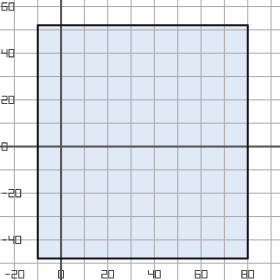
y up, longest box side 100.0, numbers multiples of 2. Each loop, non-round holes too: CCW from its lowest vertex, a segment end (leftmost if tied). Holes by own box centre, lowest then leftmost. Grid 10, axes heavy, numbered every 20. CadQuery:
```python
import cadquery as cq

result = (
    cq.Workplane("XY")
    .moveTo(-10.0, -48.0)
    .lineTo(80.0, -48.0)
    .lineTo(80.0, 52.0)
    .lineTo(-10.0, 52.0)
    .close()
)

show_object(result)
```